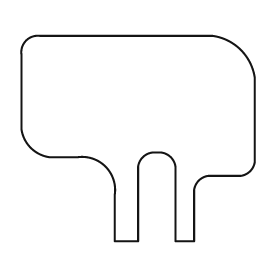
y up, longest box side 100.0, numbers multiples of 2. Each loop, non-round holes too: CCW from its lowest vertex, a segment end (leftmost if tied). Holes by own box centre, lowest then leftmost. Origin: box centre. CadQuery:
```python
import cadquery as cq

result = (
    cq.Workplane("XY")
    .moveTo(-10.0, -44.0)
    .lineTo(0.0, -44.0)
    .lineTo(0.0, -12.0)
    .threePointArc((2.0, -8.0), (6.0, -6.0))
    .lineTo(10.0, -6.0)
    .threePointArc((14.0, -8.0), (16.0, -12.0))
    .lineTo(16.0, -44.0)
    .lineTo(24.0, -44.0)
    .lineTo(24.0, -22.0)
    .threePointArc((26.0, -18.0), (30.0, -16.0))
    .lineTo(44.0, -16.0)
    .threePointArc((48.0, -14.0), (50.0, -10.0))
    .lineTo(50.0, 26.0)
    .threePointArc((44.0, 38.0), (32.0, 44.0))
    .lineTo(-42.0, 44.0)
    .threePointArc((-48.0, 42.0), (-50.0, 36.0))
    .lineTo(-50.0, 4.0)
    .threePointArc((-46.0, -4.0), (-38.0, -8.0))
    .lineTo(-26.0, -8.0)
    .threePointArc((-14.0, -12.0), (-10.0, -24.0))
    .close()
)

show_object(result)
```